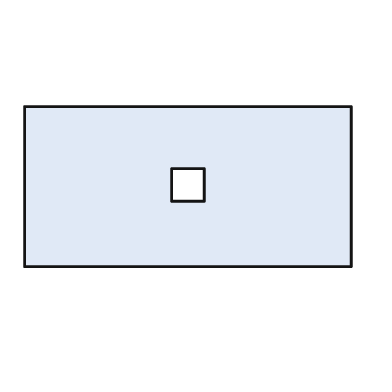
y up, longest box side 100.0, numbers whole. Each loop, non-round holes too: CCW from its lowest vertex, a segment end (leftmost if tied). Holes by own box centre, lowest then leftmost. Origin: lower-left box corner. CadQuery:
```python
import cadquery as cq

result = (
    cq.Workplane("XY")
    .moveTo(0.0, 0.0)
    .lineTo(100.0, 0.0)
    .lineTo(100.0, 49.0)
    .lineTo(0.0, 49.0)
    .close()
    .moveTo(45.0, 20.0)
    .lineTo(55.0, 20.0)
    .lineTo(55.0, 30.0)
    .lineTo(45.0, 30.0)
    .close()
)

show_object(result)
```